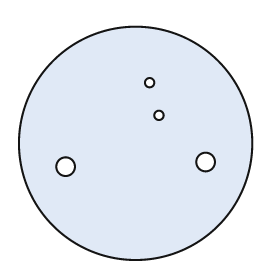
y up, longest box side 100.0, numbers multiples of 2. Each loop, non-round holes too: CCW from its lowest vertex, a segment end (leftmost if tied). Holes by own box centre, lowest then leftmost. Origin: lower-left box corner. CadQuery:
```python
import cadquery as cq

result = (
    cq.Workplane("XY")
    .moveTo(50.0, 50.0)
    .circle(50.0)
    .moveTo(20.0, 40.0)
    .circle(4.0)
    .moveTo(80.0, 42.0)
    .circle(4.0)
    .moveTo(60.0, 62.0)
    .circle(2.0)
    .moveTo(56.0, 76.0)
    .circle(2.0)
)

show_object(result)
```